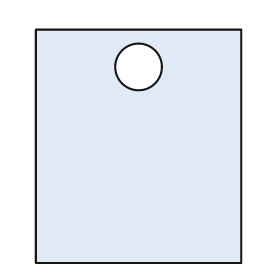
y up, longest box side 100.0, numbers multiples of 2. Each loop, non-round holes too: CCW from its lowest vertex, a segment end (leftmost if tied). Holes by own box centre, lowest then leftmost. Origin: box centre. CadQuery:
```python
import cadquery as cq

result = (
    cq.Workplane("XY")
    .moveTo(-44.0, -50.0)
    .lineTo(44.0, -50.0)
    .lineTo(44.0, 50.0)
    .lineTo(-44.0, 50.0)
    .close()
    .moveTo(0.0, 34.0)
    .circle(10.0)
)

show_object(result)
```